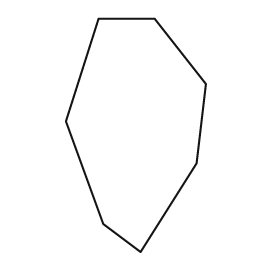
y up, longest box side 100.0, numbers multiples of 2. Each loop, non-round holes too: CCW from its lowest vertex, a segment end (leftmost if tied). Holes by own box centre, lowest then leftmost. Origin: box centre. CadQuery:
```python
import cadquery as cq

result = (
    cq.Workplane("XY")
    .moveTo(2.0, -50.0)
    .lineTo(26.0, -12.0)
    .lineTo(30.0, 22.0)
    .lineTo(8.0, 50.0)
    .lineTo(-16.0, 50.0)
    .lineTo(-30.0, 6.0)
    .lineTo(-14.0, -38.0)
    .close()
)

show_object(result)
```